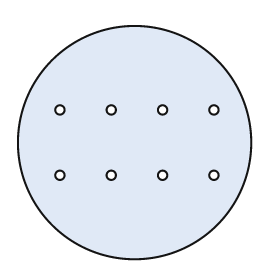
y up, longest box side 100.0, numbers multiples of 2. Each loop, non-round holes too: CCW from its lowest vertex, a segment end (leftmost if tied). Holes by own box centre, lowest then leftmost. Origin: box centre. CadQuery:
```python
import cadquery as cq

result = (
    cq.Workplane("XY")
    .moveTo(0.0, 0.0)
    .circle(50.0)
    .moveTo(-32.0, -14.0)
    .circle(2.0)
    .moveTo(-10.0, -14.0)
    .circle(2.0)
    .moveTo(12.0, -14.0)
    .circle(2.0)
    .moveTo(34.0, -14.0)
    .circle(2.0)
    .moveTo(-32.0, 14.0)
    .circle(2.0)
    .moveTo(-10.0, 14.0)
    .circle(2.0)
    .moveTo(12.0, 14.0)
    .circle(2.0)
    .moveTo(34.0, 14.0)
    .circle(2.0)
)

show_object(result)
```